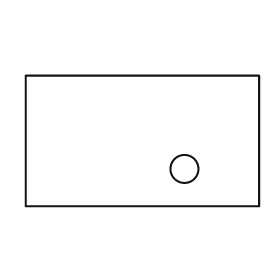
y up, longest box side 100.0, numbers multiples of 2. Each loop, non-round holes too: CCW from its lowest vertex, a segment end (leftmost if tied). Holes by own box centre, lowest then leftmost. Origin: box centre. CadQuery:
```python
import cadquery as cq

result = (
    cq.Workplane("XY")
    .moveTo(-50.0, -28.0)
    .lineTo(50.0, -28.0)
    .lineTo(50.0, 28.0)
    .lineTo(-50.0, 28.0)
    .close()
    .moveTo(18.0, -12.0)
    .circle(6.0)
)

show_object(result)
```